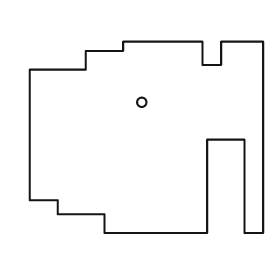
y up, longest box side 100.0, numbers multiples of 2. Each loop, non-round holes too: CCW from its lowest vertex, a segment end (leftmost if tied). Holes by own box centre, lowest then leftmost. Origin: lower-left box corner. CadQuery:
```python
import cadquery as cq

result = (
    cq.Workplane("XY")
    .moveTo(32.0, 0.0)
    .lineTo(76.0, 0.0)
    .lineTo(76.0, 40.0)
    .lineTo(92.0, 40.0)
    .lineTo(92.0, 0.0)
    .lineTo(100.0, 0.0)
    .lineTo(100.0, 82.0)
    .lineTo(82.0, 82.0)
    .lineTo(82.0, 72.0)
    .lineTo(74.0, 72.0)
    .lineTo(74.0, 82.0)
    .lineTo(40.0, 82.0)
    .lineTo(40.0, 78.0)
    .lineTo(24.0, 78.0)
    .lineTo(24.0, 70.0)
    .lineTo(0.0, 70.0)
    .lineTo(0.0, 14.0)
    .lineTo(12.0, 14.0)
    .lineTo(12.0, 8.0)
    .lineTo(32.0, 8.0)
    .close()
    .moveTo(48.0, 56.0)
    .circle(2.0)
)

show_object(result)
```